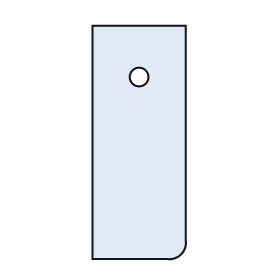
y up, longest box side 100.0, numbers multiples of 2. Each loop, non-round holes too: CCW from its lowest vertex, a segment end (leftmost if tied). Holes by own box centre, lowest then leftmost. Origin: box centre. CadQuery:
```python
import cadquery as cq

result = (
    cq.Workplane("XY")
    .moveTo(-20.0, -50.0)
    .lineTo(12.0, -50.0)
    .threePointArc((18.0, -48.0), (20.0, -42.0))
    .lineTo(20.0, 50.0)
    .lineTo(-20.0, 50.0)
    .close()
    .moveTo(0.0, 28.0)
    .circle(4.0)
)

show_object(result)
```